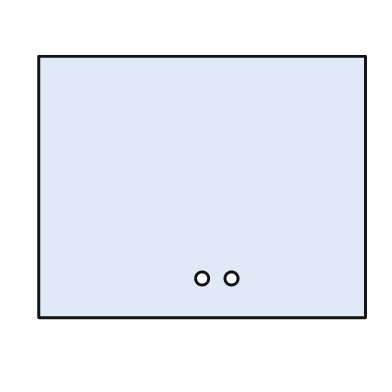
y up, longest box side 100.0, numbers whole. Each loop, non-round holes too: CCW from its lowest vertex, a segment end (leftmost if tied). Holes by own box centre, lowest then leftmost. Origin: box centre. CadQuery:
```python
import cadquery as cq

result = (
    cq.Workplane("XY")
    .moveTo(-50.0, -40.0)
    .lineTo(50.0, -40.0)
    .lineTo(50.0, 40.0)
    .lineTo(-50.0, 40.0)
    .close()
    .moveTo(0.0, -28.0)
    .circle(2.0)
    .moveTo(9.0, -28.0)
    .circle(2.0)
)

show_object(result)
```